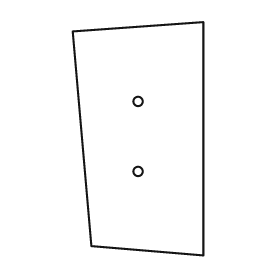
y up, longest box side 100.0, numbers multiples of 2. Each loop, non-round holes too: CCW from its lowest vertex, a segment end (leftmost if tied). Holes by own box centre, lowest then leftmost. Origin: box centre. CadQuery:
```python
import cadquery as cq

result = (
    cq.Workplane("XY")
    .moveTo(28.0, -50.0)
    .lineTo(28.0, 50.0)
    .lineTo(-28.0, 46.0)
    .lineTo(-20.0, -46.0)
    .close()
    .moveTo(0.0, -14.0)
    .circle(2.0)
    .moveTo(0.0, 16.0)
    .circle(2.0)
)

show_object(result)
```